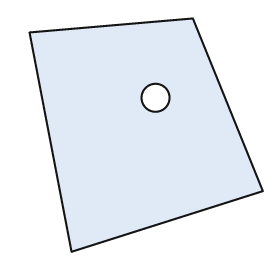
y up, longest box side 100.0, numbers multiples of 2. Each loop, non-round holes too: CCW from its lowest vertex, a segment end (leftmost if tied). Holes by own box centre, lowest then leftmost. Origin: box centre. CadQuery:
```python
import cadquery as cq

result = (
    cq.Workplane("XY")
    .moveTo(-32.0, -50.0)
    .lineTo(50.0, -24.0)
    .lineTo(20.0, 50.0)
    .lineTo(-50.0, 44.0)
    .close()
    .moveTo(4.0, 16.0)
    .circle(6.0)
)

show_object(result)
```